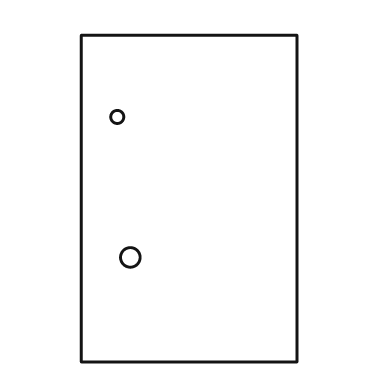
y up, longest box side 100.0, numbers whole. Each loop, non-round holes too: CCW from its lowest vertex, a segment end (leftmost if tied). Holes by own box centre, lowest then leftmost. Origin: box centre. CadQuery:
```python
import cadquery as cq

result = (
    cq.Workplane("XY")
    .moveTo(-33.0, -50.0)
    .lineTo(33.0, -50.0)
    .lineTo(33.0, 50.0)
    .lineTo(-33.0, 50.0)
    .close()
    .moveTo(-18.0, -18.0)
    .circle(3.0)
    .moveTo(-22.0, 25.0)
    .circle(2.0)
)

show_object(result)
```